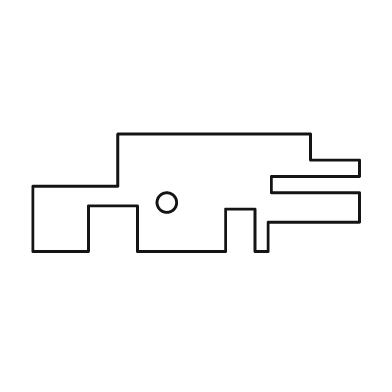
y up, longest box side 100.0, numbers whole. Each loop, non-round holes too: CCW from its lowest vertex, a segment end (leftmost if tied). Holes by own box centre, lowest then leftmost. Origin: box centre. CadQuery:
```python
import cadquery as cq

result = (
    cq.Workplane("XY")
    .moveTo(-50.0, -18.0)
    .lineTo(-33.0, -18.0)
    .lineTo(-33.0, -4.0)
    .lineTo(-18.0, -4.0)
    .lineTo(-18.0, -18.0)
    .lineTo(9.0, -18.0)
    .lineTo(9.0, -5.0)
    .lineTo(18.0, -5.0)
    .lineTo(18.0, -18.0)
    .lineTo(22.0, -18.0)
    .lineTo(22.0, -9.0)
    .lineTo(50.0, -9.0)
    .lineTo(50.0, 0.0)
    .lineTo(23.0, 0.0)
    .lineTo(23.0, 5.0)
    .lineTo(50.0, 5.0)
    .lineTo(50.0, 10.0)
    .lineTo(35.0, 10.0)
    .lineTo(35.0, 18.0)
    .lineTo(-24.0, 18.0)
    .lineTo(-24.0, 2.0)
    .lineTo(-50.0, 2.0)
    .close()
    .moveTo(-9.0, -3.0)
    .circle(3.0)
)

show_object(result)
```